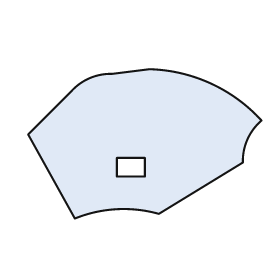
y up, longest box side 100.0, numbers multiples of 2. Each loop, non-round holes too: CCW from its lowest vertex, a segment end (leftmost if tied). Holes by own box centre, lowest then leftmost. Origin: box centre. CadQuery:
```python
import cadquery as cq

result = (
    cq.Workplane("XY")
    .moveTo(-30.0, -32.0)
    .threePointArc((-12.0, -28.0), (6.0, -30.0))
    .lineTo(42.0, -8.0)
    .threePointArc((44.0, 2.0), (50.0, 10.0))
    .threePointArc((28.0, 26.0), (2.0, 32.0))
    .lineTo(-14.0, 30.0)
    .threePointArc((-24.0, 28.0), (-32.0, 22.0))
    .lineTo(-50.0, 4.0)
    .close()
    .moveTo(-12.0, -14.0)
    .lineTo(0.0, -14.0)
    .lineTo(0.0, -6.0)
    .lineTo(-12.0, -6.0)
    .close()
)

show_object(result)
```